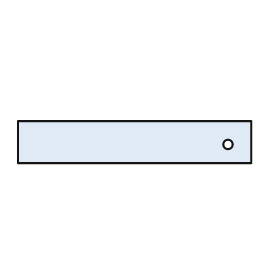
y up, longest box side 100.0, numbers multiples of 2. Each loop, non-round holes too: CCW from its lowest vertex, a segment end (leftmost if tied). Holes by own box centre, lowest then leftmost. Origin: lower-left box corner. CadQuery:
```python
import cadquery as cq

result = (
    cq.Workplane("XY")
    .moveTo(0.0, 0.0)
    .lineTo(100.0, 0.0)
    .lineTo(100.0, 18.0)
    .lineTo(0.0, 18.0)
    .close()
    .moveTo(90.0, 8.0)
    .circle(2.0)
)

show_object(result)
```